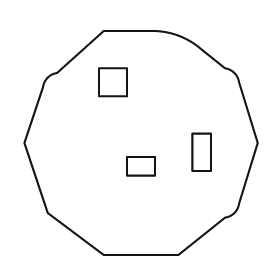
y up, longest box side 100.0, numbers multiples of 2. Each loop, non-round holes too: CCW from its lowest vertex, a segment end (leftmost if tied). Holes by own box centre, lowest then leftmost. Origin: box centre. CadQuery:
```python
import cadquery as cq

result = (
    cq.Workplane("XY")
    .moveTo(-16.0, -48.0)
    .lineTo(16.0, -48.0)
    .lineTo(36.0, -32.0)
    .threePointArc((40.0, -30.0), (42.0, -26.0))
    .lineTo(50.0, 0.0)
    .lineTo(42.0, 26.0)
    .threePointArc((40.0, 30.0), (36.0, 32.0))
    .lineTo(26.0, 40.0)
    .threePointArc((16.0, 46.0), (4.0, 48.0))
    .lineTo(-16.0, 48.0)
    .lineTo(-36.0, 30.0)
    .threePointArc((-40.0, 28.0), (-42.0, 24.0))
    .lineTo(-50.0, 0.0)
    .lineTo(-40.0, -30.0)
    .close()
    .moveTo(-6.0, -14.0)
    .lineTo(6.0, -14.0)
    .lineTo(6.0, -6.0)
    .lineTo(-6.0, -6.0)
    .close()
    .moveTo(22.0, -12.0)
    .lineTo(30.0, -12.0)
    .lineTo(30.0, 4.0)
    .lineTo(22.0, 4.0)
    .close()
    .moveTo(-18.0, 20.0)
    .lineTo(-6.0, 20.0)
    .lineTo(-6.0, 32.0)
    .lineTo(-18.0, 32.0)
    .close()
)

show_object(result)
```